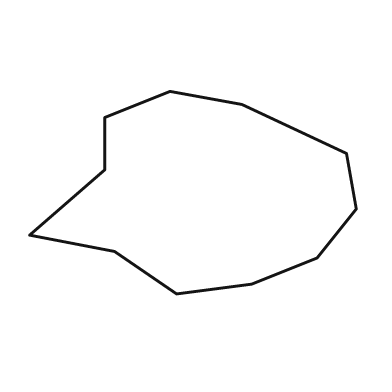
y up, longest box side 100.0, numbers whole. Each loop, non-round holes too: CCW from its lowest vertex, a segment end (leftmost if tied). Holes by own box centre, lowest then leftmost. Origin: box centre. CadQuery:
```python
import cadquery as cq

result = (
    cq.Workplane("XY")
    .moveTo(-5.0, -31.0)
    .lineTo(18.0, -28.0)
    .lineTo(38.0, -20.0)
    .lineTo(50.0, -5.0)
    .lineTo(47.0, 12.0)
    .lineTo(15.0, 27.0)
    .lineTo(-7.0, 31.0)
    .lineTo(-27.0, 23.0)
    .lineTo(-27.0, 7.0)
    .lineTo(-50.0, -13.0)
    .lineTo(-24.0, -18.0)
    .close()
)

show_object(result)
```